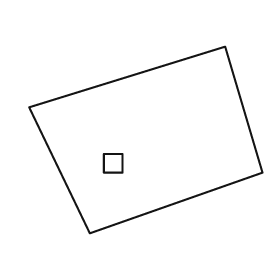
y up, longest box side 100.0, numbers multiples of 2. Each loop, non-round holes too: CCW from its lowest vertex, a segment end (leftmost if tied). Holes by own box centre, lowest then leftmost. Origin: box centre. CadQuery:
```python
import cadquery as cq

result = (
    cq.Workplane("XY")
    .moveTo(-24.0, -40.0)
    .lineTo(50.0, -14.0)
    .lineTo(34.0, 40.0)
    .lineTo(-50.0, 14.0)
    .close()
    .moveTo(-18.0, -14.0)
    .lineTo(-10.0, -14.0)
    .lineTo(-10.0, -6.0)
    .lineTo(-18.0, -6.0)
    .close()
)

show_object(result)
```